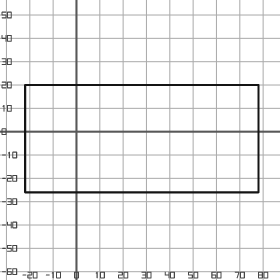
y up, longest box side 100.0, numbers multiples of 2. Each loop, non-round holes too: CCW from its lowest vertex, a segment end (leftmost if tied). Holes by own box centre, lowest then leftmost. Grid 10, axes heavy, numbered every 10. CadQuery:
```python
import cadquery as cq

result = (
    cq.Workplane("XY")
    .moveTo(-22.0, -26.0)
    .lineTo(78.0, -26.0)
    .lineTo(78.0, 20.0)
    .lineTo(-22.0, 20.0)
    .close()
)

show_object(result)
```